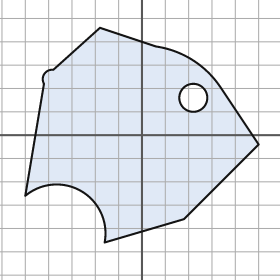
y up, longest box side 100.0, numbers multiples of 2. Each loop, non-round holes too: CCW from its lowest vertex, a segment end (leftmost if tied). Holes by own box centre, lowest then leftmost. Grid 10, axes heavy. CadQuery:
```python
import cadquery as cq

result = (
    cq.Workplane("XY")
    .moveTo(-16.0, -46.0)
    .lineTo(18.0, -36.0)
    .lineTo(50.0, -4.0)
    .lineTo(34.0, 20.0)
    .threePointArc((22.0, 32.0), (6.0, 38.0))
    .lineTo(-18.0, 46.0)
    .lineTo(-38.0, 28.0)
    .threePointArc((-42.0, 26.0), (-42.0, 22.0))
    .lineTo(-50.0, -26.0)
    .threePointArc((-26.0, -24.0), (-16.0, -46.0))
    .close()
    .moveTo(22.0, 16.0)
    .circle(6.0)
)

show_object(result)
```